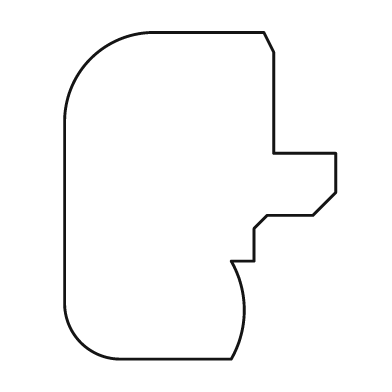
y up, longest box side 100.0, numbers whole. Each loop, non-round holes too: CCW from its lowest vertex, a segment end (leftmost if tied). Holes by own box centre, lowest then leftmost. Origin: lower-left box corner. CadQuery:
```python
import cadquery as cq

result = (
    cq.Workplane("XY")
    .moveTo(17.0, 0.0)
    .lineTo(51.0, 0.0)
    .threePointArc((55.0, 15.0), (51.0, 30.0))
    .lineTo(58.0, 30.0)
    .lineTo(58.0, 40.0)
    .lineTo(62.0, 44.0)
    .lineTo(76.0, 44.0)
    .lineTo(83.0, 51.0)
    .lineTo(83.0, 63.0)
    .lineTo(64.0, 63.0)
    .lineTo(64.0, 94.0)
    .lineTo(61.0, 100.0)
    .lineTo(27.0, 100.0)
    .threePointArc((8.0, 92.0), (0.0, 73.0))
    .lineTo(0.0, 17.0)
    .threePointArc((5.0, 5.0), (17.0, 0.0))
    .close()
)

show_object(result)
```